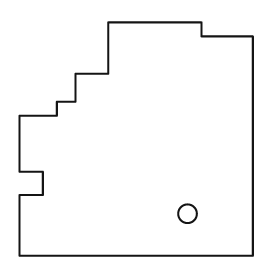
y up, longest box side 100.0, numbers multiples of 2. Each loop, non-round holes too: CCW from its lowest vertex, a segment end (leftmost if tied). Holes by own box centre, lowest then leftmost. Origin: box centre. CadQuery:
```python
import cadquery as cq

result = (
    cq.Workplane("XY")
    .moveTo(-50.0, -50.0)
    .lineTo(50.0, -50.0)
    .lineTo(50.0, 44.0)
    .lineTo(28.0, 44.0)
    .lineTo(28.0, 50.0)
    .lineTo(-12.0, 50.0)
    .lineTo(-12.0, 28.0)
    .lineTo(-26.0, 28.0)
    .lineTo(-26.0, 16.0)
    .lineTo(-34.0, 16.0)
    .lineTo(-34.0, 10.0)
    .lineTo(-50.0, 10.0)
    .lineTo(-50.0, -14.0)
    .lineTo(-40.0, -14.0)
    .lineTo(-40.0, -24.0)
    .lineTo(-50.0, -24.0)
    .close()
    .moveTo(22.0, -32.0)
    .circle(4.0)
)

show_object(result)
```